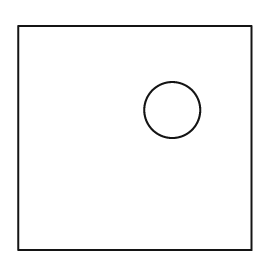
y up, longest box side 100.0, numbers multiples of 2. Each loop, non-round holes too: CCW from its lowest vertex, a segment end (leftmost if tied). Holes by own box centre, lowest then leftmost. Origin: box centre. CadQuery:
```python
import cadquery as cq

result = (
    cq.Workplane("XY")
    .moveTo(-50.0, -48.0)
    .lineTo(50.0, -48.0)
    .lineTo(50.0, 48.0)
    .lineTo(-50.0, 48.0)
    .close()
    .moveTo(16.0, 12.0)
    .circle(12.0)
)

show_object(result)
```